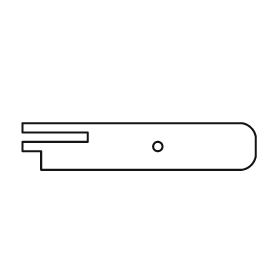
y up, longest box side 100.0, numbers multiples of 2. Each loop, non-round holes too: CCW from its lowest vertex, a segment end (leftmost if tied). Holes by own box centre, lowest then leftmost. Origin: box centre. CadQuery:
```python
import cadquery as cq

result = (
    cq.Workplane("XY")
    .moveTo(-42.0, -10.0)
    .lineTo(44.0, -10.0)
    .threePointArc((48.0, -8.0), (50.0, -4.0))
    .lineTo(50.0, 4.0)
    .threePointArc((48.0, 8.0), (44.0, 10.0))
    .lineTo(-50.0, 10.0)
    .lineTo(-50.0, 6.0)
    .lineTo(-22.0, 6.0)
    .lineTo(-22.0, 2.0)
    .lineTo(-50.0, 2.0)
    .lineTo(-50.0, -2.0)
    .lineTo(-42.0, -2.0)
    .close()
    .moveTo(8.0, 0.0)
    .circle(2.0)
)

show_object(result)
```